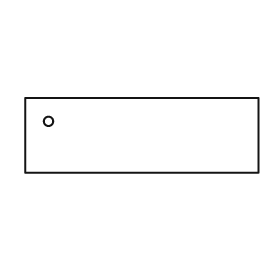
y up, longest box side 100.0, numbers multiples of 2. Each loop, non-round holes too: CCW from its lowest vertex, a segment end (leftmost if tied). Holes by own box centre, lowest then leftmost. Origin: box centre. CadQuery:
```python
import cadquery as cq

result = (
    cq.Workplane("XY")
    .moveTo(-50.0, -16.0)
    .lineTo(50.0, -16.0)
    .lineTo(50.0, 16.0)
    .lineTo(-50.0, 16.0)
    .close()
    .moveTo(-40.0, 6.0)
    .circle(2.0)
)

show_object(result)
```